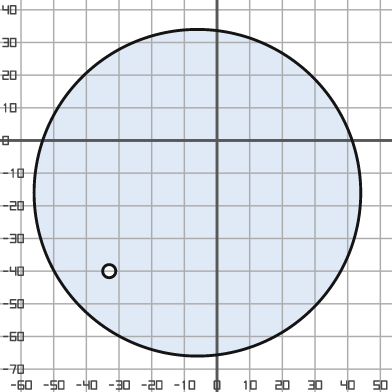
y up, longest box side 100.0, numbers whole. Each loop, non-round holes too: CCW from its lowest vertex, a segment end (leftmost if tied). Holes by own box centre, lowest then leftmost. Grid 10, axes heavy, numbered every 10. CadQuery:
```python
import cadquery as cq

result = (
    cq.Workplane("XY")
    .moveTo(-6.0, -16.0)
    .circle(50.0)
    .moveTo(-33.0, -40.0)
    .circle(2.0)
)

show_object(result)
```